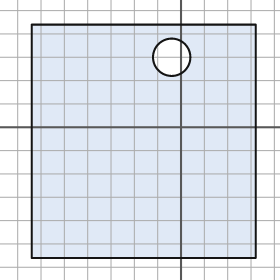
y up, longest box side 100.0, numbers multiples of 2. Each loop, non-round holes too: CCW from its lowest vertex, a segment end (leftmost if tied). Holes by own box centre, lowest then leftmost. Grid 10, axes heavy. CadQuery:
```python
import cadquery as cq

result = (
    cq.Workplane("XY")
    .moveTo(-64.0, -56.0)
    .lineTo(32.0, -56.0)
    .lineTo(32.0, 44.0)
    .lineTo(-64.0, 44.0)
    .close()
    .moveTo(-4.0, 30.0)
    .circle(8.0)
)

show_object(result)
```